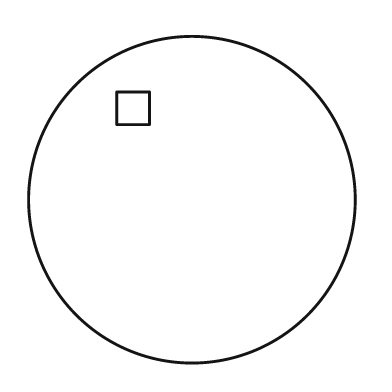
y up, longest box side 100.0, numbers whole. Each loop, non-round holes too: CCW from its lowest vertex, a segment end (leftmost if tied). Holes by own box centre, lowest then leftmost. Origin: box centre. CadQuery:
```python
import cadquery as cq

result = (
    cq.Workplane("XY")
    .moveTo(0.0, 0.0)
    .circle(50.0)
    .moveTo(-23.0, 23.0)
    .lineTo(-13.0, 23.0)
    .lineTo(-13.0, 33.0)
    .lineTo(-23.0, 33.0)
    .close()
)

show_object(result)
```